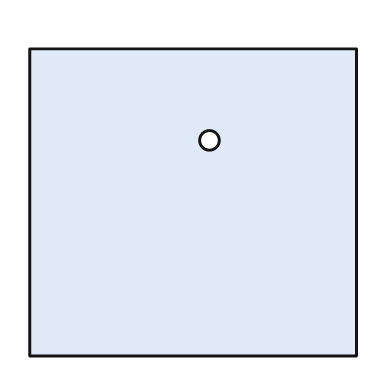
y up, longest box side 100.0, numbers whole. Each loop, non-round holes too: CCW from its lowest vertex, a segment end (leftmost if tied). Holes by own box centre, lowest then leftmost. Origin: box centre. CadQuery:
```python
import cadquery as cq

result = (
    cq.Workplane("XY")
    .moveTo(-50.0, -47.0)
    .lineTo(50.0, -47.0)
    .lineTo(50.0, 47.0)
    .lineTo(-50.0, 47.0)
    .close()
    .moveTo(5.0, 19.0)
    .circle(3.0)
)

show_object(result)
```